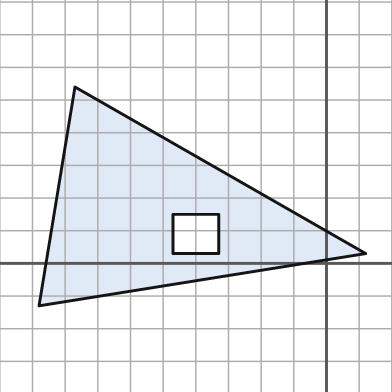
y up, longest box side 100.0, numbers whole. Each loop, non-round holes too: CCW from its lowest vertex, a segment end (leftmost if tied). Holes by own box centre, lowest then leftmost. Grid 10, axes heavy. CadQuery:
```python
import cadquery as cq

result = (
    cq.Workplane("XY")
    .moveTo(-88.0, -13.0)
    .lineTo(12.0, 3.0)
    .lineTo(-77.0, 54.0)
    .close()
    .moveTo(-47.0, 3.0)
    .lineTo(-33.0, 3.0)
    .lineTo(-33.0, 15.0)
    .lineTo(-47.0, 15.0)
    .close()
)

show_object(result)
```